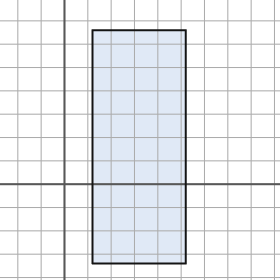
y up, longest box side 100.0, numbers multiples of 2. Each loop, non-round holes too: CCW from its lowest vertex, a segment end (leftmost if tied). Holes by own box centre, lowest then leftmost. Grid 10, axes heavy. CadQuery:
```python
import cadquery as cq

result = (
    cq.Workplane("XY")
    .moveTo(12.0, -34.0)
    .lineTo(52.0, -34.0)
    .lineTo(52.0, 66.0)
    .lineTo(12.0, 66.0)
    .close()
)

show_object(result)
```